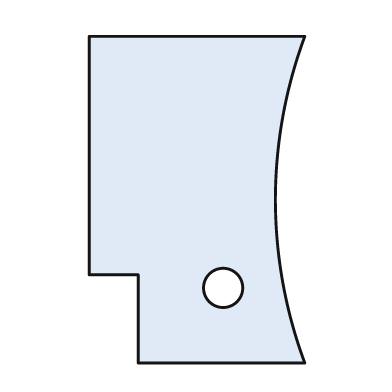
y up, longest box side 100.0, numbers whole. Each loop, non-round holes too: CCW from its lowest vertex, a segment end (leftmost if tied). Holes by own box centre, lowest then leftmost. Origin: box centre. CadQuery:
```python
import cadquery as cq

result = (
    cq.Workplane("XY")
    .moveTo(-18.0, -50.0)
    .lineTo(33.0, -50.0)
    .threePointArc((24.0, 0.0), (33.0, 50.0))
    .lineTo(-33.0, 50.0)
    .lineTo(-33.0, -23.0)
    .lineTo(-18.0, -23.0)
    .close()
    .moveTo(8.0, -27.0)
    .circle(6.0)
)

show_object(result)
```